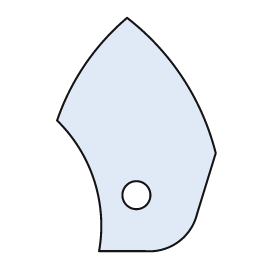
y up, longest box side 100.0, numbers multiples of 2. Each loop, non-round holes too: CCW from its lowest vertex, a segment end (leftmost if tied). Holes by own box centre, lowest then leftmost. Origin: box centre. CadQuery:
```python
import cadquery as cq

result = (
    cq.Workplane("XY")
    .moveTo(-16.0, -50.0)
    .lineTo(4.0, -50.0)
    .threePointArc((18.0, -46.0), (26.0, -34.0))
    .lineTo(34.0, -8.0)
    .threePointArc((20.0, 24.0), (-4.0, 50.0))
    .threePointArc((-22.0, 30.0), (-34.0, 6.0))
    .threePointArc((-18.0, -20.0), (-16.0, -50.0))
    .close()
    .moveTo(0.0, -26.0)
    .circle(6.0)
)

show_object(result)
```